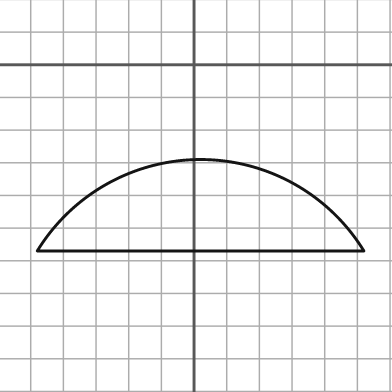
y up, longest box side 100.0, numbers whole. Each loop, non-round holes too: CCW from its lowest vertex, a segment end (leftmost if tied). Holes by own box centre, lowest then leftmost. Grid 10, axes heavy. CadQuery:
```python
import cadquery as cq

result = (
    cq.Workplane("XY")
    .moveTo(-48.0, -57.0)
    .lineTo(52.0, -57.0)
    .threePointArc((2.0, -29.0), (-48.0, -57.0))
    .close()
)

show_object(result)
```